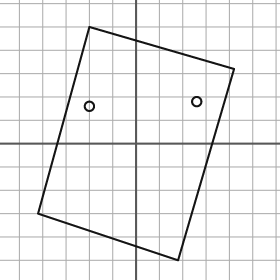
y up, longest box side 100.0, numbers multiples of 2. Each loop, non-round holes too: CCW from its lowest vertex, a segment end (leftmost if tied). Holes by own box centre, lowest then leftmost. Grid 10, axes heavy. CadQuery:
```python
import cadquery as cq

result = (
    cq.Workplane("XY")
    .moveTo(18.0, -50.0)
    .lineTo(42.0, 32.0)
    .lineTo(-20.0, 50.0)
    .lineTo(-42.0, -30.0)
    .close()
    .moveTo(-20.0, 16.0)
    .circle(2.0)
    .moveTo(26.0, 18.0)
    .circle(2.0)
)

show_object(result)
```